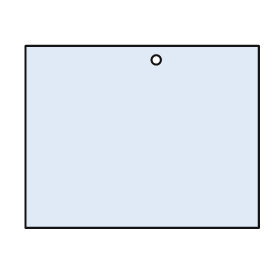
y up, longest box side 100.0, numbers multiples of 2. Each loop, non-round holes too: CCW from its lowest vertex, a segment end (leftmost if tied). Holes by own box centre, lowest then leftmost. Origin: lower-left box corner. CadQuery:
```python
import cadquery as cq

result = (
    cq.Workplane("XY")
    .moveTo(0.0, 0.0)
    .lineTo(100.0, 0.0)
    .lineTo(100.0, 78.0)
    .lineTo(0.0, 78.0)
    .close()
    .moveTo(56.0, 72.0)
    .circle(2.0)
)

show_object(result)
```